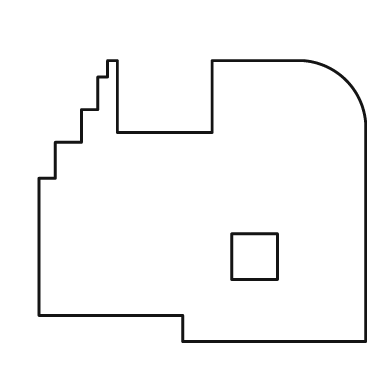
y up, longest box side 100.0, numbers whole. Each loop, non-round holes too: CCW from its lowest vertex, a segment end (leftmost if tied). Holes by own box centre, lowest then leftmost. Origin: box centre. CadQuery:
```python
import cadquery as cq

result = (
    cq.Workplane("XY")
    .moveTo(-6.0, -43.0)
    .lineTo(50.0, -43.0)
    .lineTo(50.0, 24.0)
    .threePointArc((44.0, 37.0), (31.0, 43.0))
    .lineTo(3.0, 43.0)
    .lineTo(3.0, 21.0)
    .lineTo(-26.0, 21.0)
    .lineTo(-26.0, 43.0)
    .lineTo(-29.0, 43.0)
    .lineTo(-29.0, 38.0)
    .lineTo(-32.0, 38.0)
    .lineTo(-32.0, 28.0)
    .lineTo(-37.0, 28.0)
    .lineTo(-37.0, 18.0)
    .lineTo(-45.0, 18.0)
    .lineTo(-45.0, 7.0)
    .lineTo(-50.0, 7.0)
    .lineTo(-50.0, -35.0)
    .lineTo(-6.0, -35.0)
    .close()
    .moveTo(9.0, -24.0)
    .lineTo(23.0, -24.0)
    .lineTo(23.0, -10.0)
    .lineTo(9.0, -10.0)
    .close()
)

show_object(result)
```